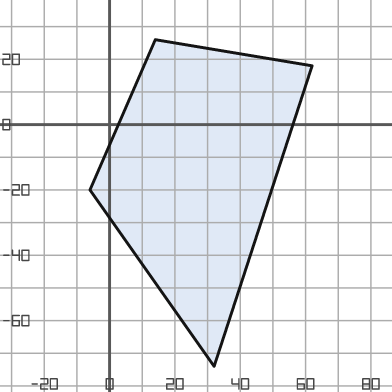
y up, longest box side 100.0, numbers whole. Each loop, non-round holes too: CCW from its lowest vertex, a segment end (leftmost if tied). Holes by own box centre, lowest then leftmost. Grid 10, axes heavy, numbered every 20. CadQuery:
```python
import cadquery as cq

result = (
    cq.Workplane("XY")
    .moveTo(32.0, -74.0)
    .lineTo(62.0, 18.0)
    .lineTo(14.0, 26.0)
    .lineTo(-6.0, -20.0)
    .close()
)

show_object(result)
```